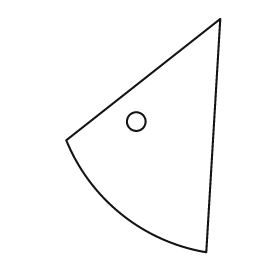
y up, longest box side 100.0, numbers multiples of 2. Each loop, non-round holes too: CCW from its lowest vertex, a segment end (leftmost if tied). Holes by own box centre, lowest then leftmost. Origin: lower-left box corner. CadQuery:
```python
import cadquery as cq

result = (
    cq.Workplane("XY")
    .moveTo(60.0, 0.0)
    .lineTo(66.0, 100.0)
    .lineTo(0.0, 48.0)
    .threePointArc((24.0, 16.0), (60.0, 0.0))
    .close()
    .moveTo(30.0, 56.0)
    .circle(4.0)
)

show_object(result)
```